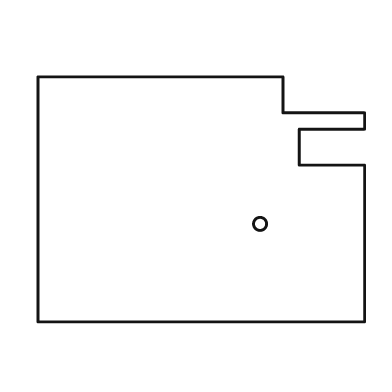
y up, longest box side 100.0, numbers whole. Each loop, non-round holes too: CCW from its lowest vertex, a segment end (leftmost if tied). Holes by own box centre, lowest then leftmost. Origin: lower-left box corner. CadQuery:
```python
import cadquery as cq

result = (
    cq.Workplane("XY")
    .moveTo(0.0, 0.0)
    .lineTo(100.0, 0.0)
    .lineTo(100.0, 48.0)
    .lineTo(80.0, 48.0)
    .lineTo(80.0, 59.0)
    .lineTo(100.0, 59.0)
    .lineTo(100.0, 64.0)
    .lineTo(75.0, 64.0)
    .lineTo(75.0, 75.0)
    .lineTo(0.0, 75.0)
    .close()
    .moveTo(68.0, 30.0)
    .circle(2.0)
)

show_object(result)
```